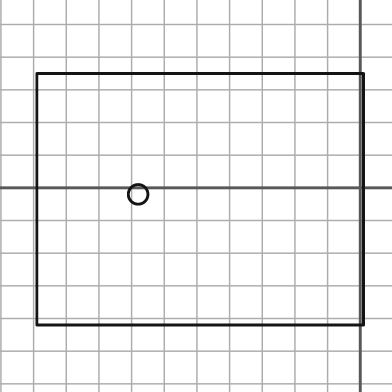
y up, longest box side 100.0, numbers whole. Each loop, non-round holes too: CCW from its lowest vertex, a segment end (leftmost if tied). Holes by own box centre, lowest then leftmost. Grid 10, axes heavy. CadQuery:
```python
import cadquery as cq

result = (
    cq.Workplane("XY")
    .moveTo(-99.0, -42.0)
    .lineTo(1.0, -42.0)
    .lineTo(1.0, 35.0)
    .lineTo(-99.0, 35.0)
    .close()
    .moveTo(-68.0, -2.0)
    .circle(3.0)
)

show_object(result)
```